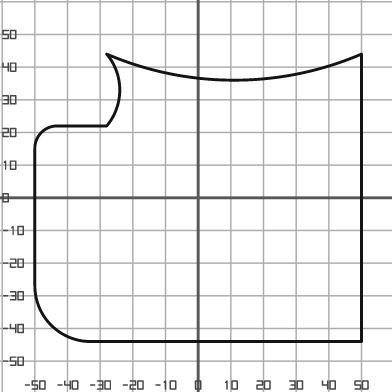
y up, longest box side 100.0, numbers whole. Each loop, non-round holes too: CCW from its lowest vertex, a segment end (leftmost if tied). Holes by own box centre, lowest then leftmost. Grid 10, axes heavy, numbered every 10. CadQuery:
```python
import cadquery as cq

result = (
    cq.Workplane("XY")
    .moveTo(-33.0, -44.0)
    .lineTo(50.0, -44.0)
    .lineTo(50.0, 44.0)
    .threePointArc((11.0, 36.0), (-28.0, 44.0))
    .threePointArc((-24.0, 33.0), (-28.0, 22.0))
    .lineTo(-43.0, 22.0)
    .threePointArc((-48.0, 20.0), (-50.0, 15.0))
    .lineTo(-50.0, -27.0)
    .threePointArc((-45.0, -39.0), (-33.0, -44.0))
    .close()
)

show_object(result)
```